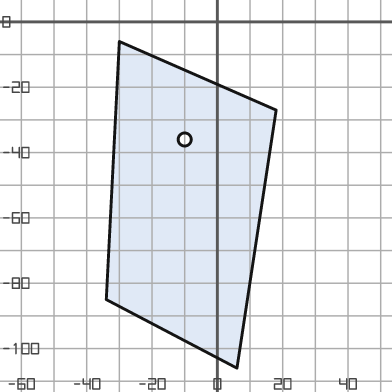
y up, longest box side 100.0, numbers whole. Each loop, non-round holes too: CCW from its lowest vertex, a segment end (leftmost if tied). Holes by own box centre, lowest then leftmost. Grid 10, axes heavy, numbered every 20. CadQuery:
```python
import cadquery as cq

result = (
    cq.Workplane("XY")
    .moveTo(6.0, -106.0)
    .lineTo(18.0, -27.0)
    .lineTo(-30.0, -6.0)
    .lineTo(-34.0, -85.0)
    .close()
    .moveTo(-10.0, -36.0)
    .circle(2.0)
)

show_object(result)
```